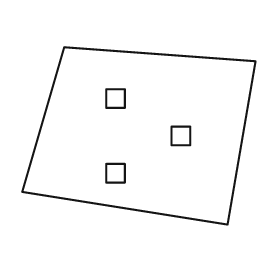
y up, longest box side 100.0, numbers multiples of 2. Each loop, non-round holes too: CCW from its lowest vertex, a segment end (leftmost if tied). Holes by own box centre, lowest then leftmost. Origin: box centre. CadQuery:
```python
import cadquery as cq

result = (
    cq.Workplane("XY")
    .moveTo(38.0, -38.0)
    .lineTo(50.0, 32.0)
    .lineTo(-32.0, 38.0)
    .lineTo(-50.0, -24.0)
    .close()
    .moveTo(-14.0, -20.0)
    .lineTo(-6.0, -20.0)
    .lineTo(-6.0, -12.0)
    .lineTo(-14.0, -12.0)
    .close()
    .moveTo(14.0, -4.0)
    .lineTo(22.0, -4.0)
    .lineTo(22.0, 4.0)
    .lineTo(14.0, 4.0)
    .close()
    .moveTo(-14.0, 12.0)
    .lineTo(-6.0, 12.0)
    .lineTo(-6.0, 20.0)
    .lineTo(-14.0, 20.0)
    .close()
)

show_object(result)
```